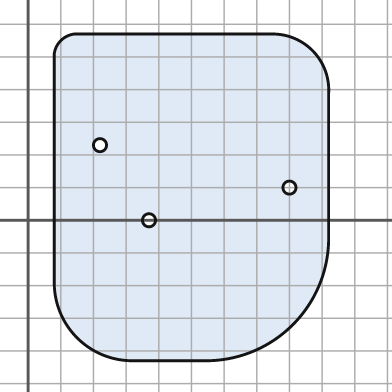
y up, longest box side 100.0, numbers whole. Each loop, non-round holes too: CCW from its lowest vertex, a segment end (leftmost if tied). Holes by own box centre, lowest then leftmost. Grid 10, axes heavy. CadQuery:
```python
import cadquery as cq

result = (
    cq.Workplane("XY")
    .moveTo(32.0, -43.0)
    .lineTo(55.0, -43.0)
    .threePointArc((81.0, -32.0), (92.0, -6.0))
    .lineTo(92.0, 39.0)
    .threePointArc((87.0, 52.0), (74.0, 57.0))
    .lineTo(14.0, 57.0)
    .threePointArc((10.0, 55.0), (8.0, 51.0))
    .lineTo(8.0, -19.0)
    .threePointArc((15.0, -36.0), (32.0, -43.0))
    .close()
    .moveTo(37.0, 0.0)
    .circle(2.0)
    .moveTo(80.0, 10.0)
    .circle(2.0)
    .moveTo(22.0, 23.0)
    .circle(2.0)
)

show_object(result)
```